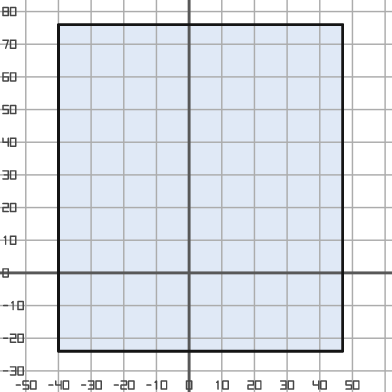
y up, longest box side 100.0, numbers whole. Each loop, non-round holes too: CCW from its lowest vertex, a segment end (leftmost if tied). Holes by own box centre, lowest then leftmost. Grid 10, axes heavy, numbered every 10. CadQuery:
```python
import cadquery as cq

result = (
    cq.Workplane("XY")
    .moveTo(-40.0, -24.0)
    .lineTo(47.0, -24.0)
    .lineTo(47.0, 76.0)
    .lineTo(-40.0, 76.0)
    .close()
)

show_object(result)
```